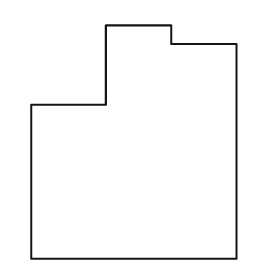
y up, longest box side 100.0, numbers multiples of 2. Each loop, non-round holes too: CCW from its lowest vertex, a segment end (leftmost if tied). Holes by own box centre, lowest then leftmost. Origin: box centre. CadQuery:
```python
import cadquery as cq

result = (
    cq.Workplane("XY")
    .moveTo(-44.0, -50.0)
    .lineTo(44.0, -50.0)
    .lineTo(44.0, 42.0)
    .lineTo(16.0, 42.0)
    .lineTo(16.0, 50.0)
    .lineTo(-12.0, 50.0)
    .lineTo(-12.0, 16.0)
    .lineTo(-44.0, 16.0)
    .close()
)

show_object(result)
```